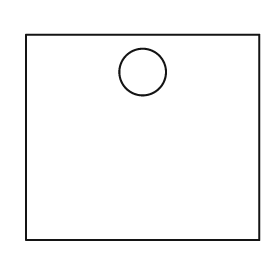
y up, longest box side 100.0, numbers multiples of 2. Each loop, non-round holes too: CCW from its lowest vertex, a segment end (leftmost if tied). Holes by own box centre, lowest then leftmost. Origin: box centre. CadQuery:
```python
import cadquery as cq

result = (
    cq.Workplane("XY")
    .moveTo(-50.0, -44.0)
    .lineTo(50.0, -44.0)
    .lineTo(50.0, 44.0)
    .lineTo(-50.0, 44.0)
    .close()
    .moveTo(0.0, 28.0)
    .circle(10.0)
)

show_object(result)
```